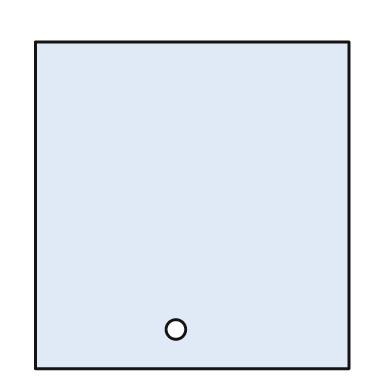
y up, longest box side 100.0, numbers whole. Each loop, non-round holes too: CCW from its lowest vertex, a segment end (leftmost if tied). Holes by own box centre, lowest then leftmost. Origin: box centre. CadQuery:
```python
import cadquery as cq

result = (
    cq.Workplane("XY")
    .moveTo(-48.0, -50.0)
    .lineTo(48.0, -50.0)
    .lineTo(48.0, 50.0)
    .lineTo(-48.0, 50.0)
    .close()
    .moveTo(-5.0, -38.0)
    .circle(3.0)
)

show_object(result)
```